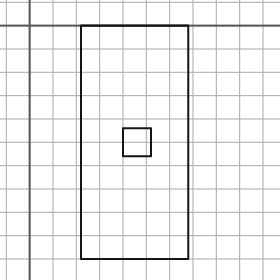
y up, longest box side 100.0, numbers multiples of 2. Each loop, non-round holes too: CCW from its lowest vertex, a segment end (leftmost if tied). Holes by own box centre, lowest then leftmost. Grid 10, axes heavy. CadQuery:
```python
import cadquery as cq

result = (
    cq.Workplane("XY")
    .moveTo(22.0, -100.0)
    .lineTo(68.0, -100.0)
    .lineTo(68.0, 0.0)
    .lineTo(22.0, 0.0)
    .close()
    .moveTo(40.0, -56.0)
    .lineTo(52.0, -56.0)
    .lineTo(52.0, -44.0)
    .lineTo(40.0, -44.0)
    .close()
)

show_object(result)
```